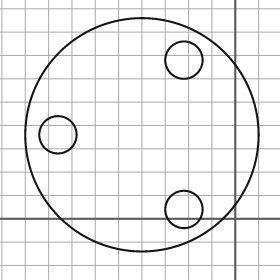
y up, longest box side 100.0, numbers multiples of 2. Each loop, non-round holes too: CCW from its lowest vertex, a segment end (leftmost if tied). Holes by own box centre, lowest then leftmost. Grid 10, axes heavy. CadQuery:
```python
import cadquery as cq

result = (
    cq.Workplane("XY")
    .moveTo(-40.0, 36.0)
    .circle(50.0)
    .moveTo(-22.0, 4.0)
    .circle(8.0)
    .moveTo(-76.0, 36.0)
    .circle(8.0)
    .moveTo(-22.0, 68.0)
    .circle(8.0)
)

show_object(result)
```